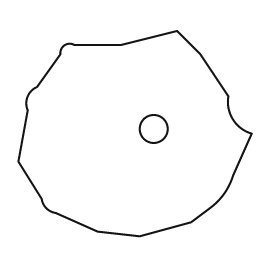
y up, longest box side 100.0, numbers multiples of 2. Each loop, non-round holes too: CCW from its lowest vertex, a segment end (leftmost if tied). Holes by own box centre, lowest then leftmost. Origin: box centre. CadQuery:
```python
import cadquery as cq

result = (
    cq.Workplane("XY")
    .moveTo(2.0, -44.0)
    .lineTo(24.0, -38.0)
    .lineTo(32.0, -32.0)
    .threePointArc((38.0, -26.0), (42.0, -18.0))
    .lineTo(50.0, 0.0)
    .threePointArc((42.0, 6.0), (40.0, 16.0))
    .lineTo(28.0, 34.0)
    .lineTo(18.0, 44.0)
    .lineTo(-6.0, 38.0)
    .lineTo(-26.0, 38.0)
    .threePointArc((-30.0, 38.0), (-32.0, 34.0))
    .lineTo(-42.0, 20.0)
    .threePointArc((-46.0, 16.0), (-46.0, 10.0))
    .lineTo(-50.0, -12.0)
    .lineTo(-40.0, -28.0)
    .threePointArc((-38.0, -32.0), (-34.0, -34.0))
    .lineTo(-16.0, -42.0)
    .close()
    .moveTo(8.0, 2.0)
    .circle(6.0)
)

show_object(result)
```